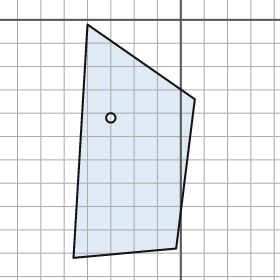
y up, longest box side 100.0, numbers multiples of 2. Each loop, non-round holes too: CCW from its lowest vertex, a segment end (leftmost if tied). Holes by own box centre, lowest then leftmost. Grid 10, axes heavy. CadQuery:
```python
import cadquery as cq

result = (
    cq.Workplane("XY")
    .moveTo(-46.0, -102.0)
    .lineTo(-2.0, -98.0)
    .lineTo(6.0, -34.0)
    .lineTo(-40.0, -2.0)
    .close()
    .moveTo(-30.0, -42.0)
    .circle(2.0)
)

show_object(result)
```